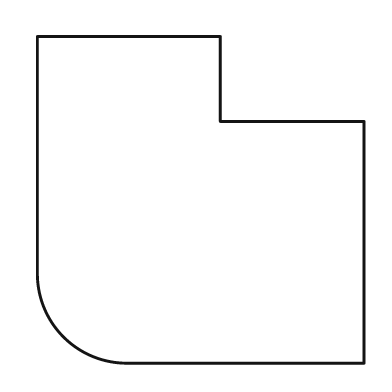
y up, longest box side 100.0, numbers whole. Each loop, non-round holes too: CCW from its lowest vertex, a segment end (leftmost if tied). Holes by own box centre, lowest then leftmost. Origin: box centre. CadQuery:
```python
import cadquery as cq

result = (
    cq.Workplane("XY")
    .moveTo(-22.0, -50.0)
    .lineTo(50.0, -50.0)
    .lineTo(50.0, 24.0)
    .lineTo(6.0, 24.0)
    .lineTo(6.0, 50.0)
    .lineTo(-50.0, 50.0)
    .lineTo(-50.0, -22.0)
    .threePointArc((-42.0, -42.0), (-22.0, -50.0))
    .close()
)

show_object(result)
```